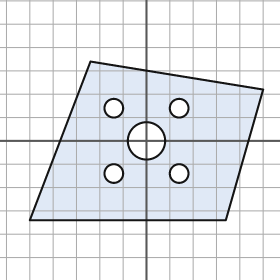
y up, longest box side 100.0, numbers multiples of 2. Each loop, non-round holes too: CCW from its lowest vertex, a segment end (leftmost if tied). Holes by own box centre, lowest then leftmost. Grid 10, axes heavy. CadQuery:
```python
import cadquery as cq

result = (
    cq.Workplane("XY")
    .moveTo(-50.0, -34.0)
    .lineTo(34.0, -34.0)
    .lineTo(50.0, 22.0)
    .lineTo(-24.0, 34.0)
    .close()
    .moveTo(-14.0, -14.0)
    .circle(4.0)
    .moveTo(14.0, -14.0)
    .circle(4.0)
    .moveTo(0.0, 0.0)
    .circle(8.0)
    .moveTo(-14.0, 14.0)
    .circle(4.0)
    .moveTo(14.0, 14.0)
    .circle(4.0)
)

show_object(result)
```